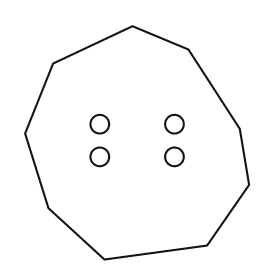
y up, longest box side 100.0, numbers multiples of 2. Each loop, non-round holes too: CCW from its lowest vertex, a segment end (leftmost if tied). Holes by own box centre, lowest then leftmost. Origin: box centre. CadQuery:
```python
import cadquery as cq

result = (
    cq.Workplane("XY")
    .moveTo(-14.0, -50.0)
    .lineTo(30.0, -44.0)
    .lineTo(48.0, -18.0)
    .lineTo(44.0, 6.0)
    .lineTo(22.0, 40.0)
    .lineTo(-2.0, 50.0)
    .lineTo(-36.0, 34.0)
    .lineTo(-48.0, 4.0)
    .lineTo(-38.0, -28.0)
    .close()
    .moveTo(-16.0, -6.0)
    .circle(4.0)
    .moveTo(16.0, -6.0)
    .circle(4.0)
    .moveTo(-16.0, 8.0)
    .circle(4.0)
    .moveTo(16.0, 8.0)
    .circle(4.0)
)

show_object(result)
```